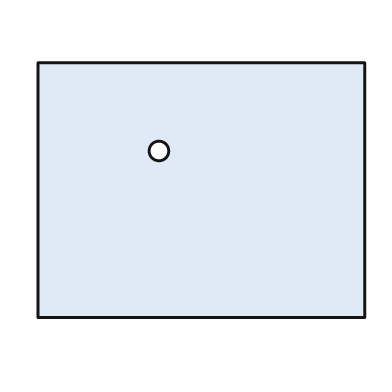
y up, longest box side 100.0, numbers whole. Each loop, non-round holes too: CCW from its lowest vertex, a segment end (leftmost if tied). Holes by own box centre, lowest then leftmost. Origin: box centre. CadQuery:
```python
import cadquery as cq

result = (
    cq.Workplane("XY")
    .moveTo(-50.0, -39.0)
    .lineTo(50.0, -39.0)
    .lineTo(50.0, 39.0)
    .lineTo(-50.0, 39.0)
    .close()
    .moveTo(-13.0, 12.0)
    .circle(3.0)
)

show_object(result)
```